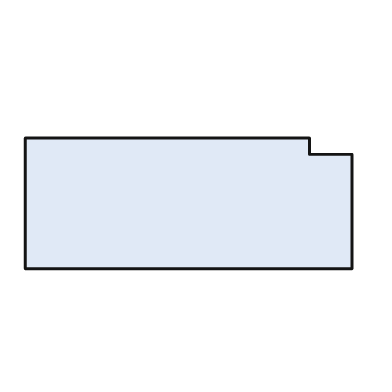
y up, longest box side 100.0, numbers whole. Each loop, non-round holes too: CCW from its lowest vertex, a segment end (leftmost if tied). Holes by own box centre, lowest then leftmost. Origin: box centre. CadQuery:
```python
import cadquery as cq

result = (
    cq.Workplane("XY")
    .moveTo(-50.0, -20.0)
    .lineTo(50.0, -20.0)
    .lineTo(50.0, 15.0)
    .lineTo(37.0, 15.0)
    .lineTo(37.0, 20.0)
    .lineTo(-50.0, 20.0)
    .close()
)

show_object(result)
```